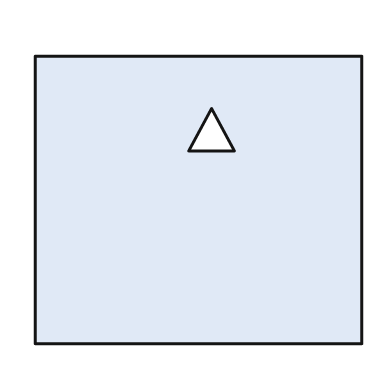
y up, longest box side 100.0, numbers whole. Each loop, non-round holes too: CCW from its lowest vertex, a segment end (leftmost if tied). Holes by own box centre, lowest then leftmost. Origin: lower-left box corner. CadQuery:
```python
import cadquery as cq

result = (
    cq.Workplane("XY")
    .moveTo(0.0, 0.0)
    .lineTo(100.0, 0.0)
    .lineTo(100.0, 88.0)
    .lineTo(0.0, 88.0)
    .close()
    .moveTo(47.0, 59.0)
    .lineTo(61.0, 59.0)
    .lineTo(54.0, 72.0)
    .close()
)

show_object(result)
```